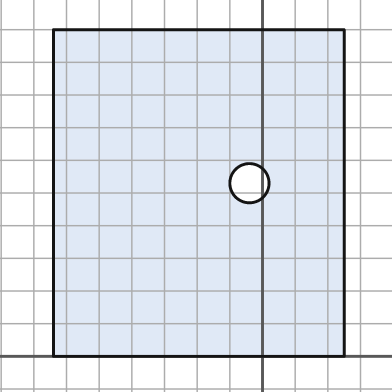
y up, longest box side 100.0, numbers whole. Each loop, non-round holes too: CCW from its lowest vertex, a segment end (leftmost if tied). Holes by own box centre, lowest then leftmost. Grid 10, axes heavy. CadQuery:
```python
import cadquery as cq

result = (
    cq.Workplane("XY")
    .moveTo(-64.0, 0.0)
    .lineTo(25.0, 0.0)
    .lineTo(25.0, 100.0)
    .lineTo(-64.0, 100.0)
    .close()
    .moveTo(-4.0, 53.0)
    .circle(6.0)
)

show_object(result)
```